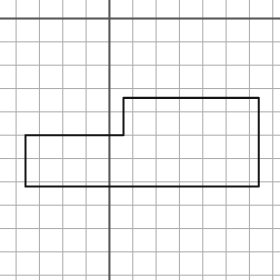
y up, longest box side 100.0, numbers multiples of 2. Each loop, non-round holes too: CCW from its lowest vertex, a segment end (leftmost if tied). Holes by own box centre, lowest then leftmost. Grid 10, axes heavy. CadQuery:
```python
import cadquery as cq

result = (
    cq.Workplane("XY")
    .moveTo(-36.0, -72.0)
    .lineTo(64.0, -72.0)
    .lineTo(64.0, -34.0)
    .lineTo(6.0, -34.0)
    .lineTo(6.0, -50.0)
    .lineTo(-36.0, -50.0)
    .close()
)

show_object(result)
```